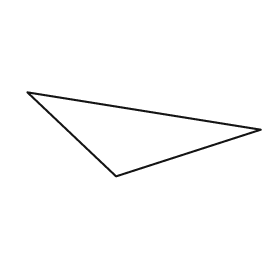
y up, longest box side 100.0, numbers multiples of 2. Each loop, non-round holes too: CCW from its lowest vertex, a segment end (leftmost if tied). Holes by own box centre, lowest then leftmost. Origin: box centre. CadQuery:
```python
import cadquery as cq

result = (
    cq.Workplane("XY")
    .moveTo(-12.0, -18.0)
    .lineTo(50.0, 2.0)
    .lineTo(-50.0, 18.0)
    .close()
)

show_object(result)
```